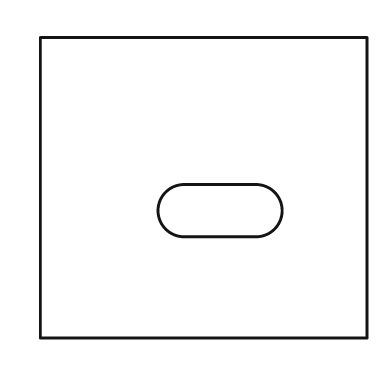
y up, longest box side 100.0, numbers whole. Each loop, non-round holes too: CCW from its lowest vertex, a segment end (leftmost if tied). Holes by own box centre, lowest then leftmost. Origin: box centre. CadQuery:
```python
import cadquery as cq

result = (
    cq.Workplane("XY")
    .moveTo(-50.0, -46.0)
    .lineTo(50.0, -46.0)
    .lineTo(50.0, 46.0)
    .lineTo(-50.0, 46.0)
    .close()
    .moveTo(-6.0, -15.0)
    .lineTo(16.0, -15.0)
    .threePointArc((24.0, -7.0), (16.0, 1.0))
    .lineTo(-6.0, 1.0)
    .threePointArc((-14.0, -7.0), (-6.0, -15.0))
    .close()
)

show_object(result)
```